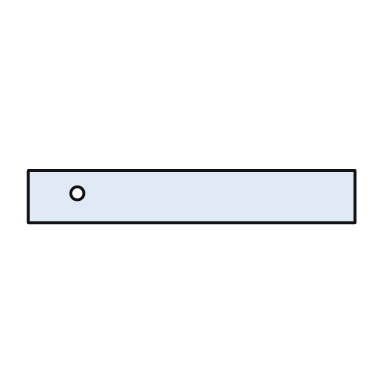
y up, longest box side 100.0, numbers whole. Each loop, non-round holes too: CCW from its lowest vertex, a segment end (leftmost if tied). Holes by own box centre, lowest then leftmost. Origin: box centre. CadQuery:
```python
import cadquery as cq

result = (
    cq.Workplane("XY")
    .moveTo(-50.0, -8.0)
    .lineTo(50.0, -8.0)
    .lineTo(50.0, 8.0)
    .lineTo(-50.0, 8.0)
    .close()
    .moveTo(-35.0, 1.0)
    .circle(2.0)
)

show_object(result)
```